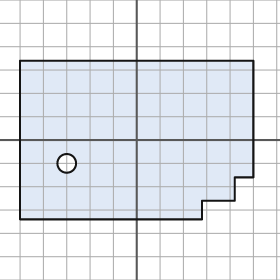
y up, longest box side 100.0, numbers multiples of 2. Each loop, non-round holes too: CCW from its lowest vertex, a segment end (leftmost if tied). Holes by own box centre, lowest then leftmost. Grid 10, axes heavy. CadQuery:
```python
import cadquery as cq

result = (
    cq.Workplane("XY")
    .moveTo(-50.0, -34.0)
    .lineTo(28.0, -34.0)
    .lineTo(28.0, -26.0)
    .lineTo(42.0, -26.0)
    .lineTo(42.0, -16.0)
    .lineTo(50.0, -16.0)
    .lineTo(50.0, 34.0)
    .lineTo(-50.0, 34.0)
    .close()
    .moveTo(-30.0, -10.0)
    .circle(4.0)
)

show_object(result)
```